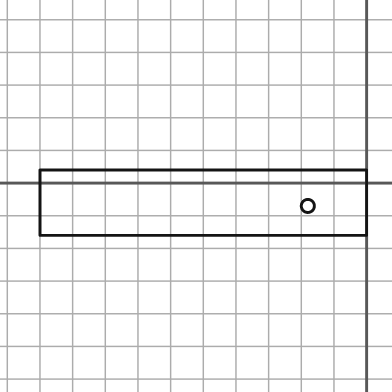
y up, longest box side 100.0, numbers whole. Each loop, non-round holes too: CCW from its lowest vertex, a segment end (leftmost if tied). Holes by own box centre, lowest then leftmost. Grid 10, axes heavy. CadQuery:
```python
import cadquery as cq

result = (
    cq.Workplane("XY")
    .moveTo(-100.0, -16.0)
    .lineTo(0.0, -16.0)
    .lineTo(0.0, 4.0)
    .lineTo(-100.0, 4.0)
    .close()
    .moveTo(-18.0, -7.0)
    .circle(2.0)
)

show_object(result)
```